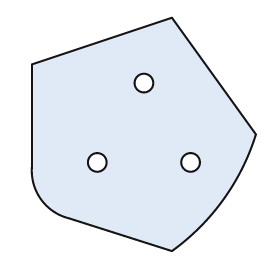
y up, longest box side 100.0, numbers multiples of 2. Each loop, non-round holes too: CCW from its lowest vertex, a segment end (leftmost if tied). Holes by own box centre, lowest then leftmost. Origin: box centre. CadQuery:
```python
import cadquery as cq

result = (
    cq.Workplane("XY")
    .moveTo(12.0, -50.0)
    .threePointArc((34.0, -28.0), (48.0, 0.0))
    .lineTo(12.0, 50.0)
    .lineTo(-48.0, 30.0)
    .lineTo(-48.0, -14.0)
    .threePointArc((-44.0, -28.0), (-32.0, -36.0))
    .close()
    .moveTo(-20.0, -12.0)
    .circle(4.0)
    .moveTo(20.0, -12.0)
    .circle(4.0)
    .moveTo(0.0, 22.0)
    .circle(4.0)
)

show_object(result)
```